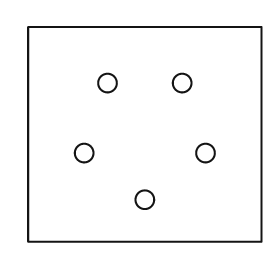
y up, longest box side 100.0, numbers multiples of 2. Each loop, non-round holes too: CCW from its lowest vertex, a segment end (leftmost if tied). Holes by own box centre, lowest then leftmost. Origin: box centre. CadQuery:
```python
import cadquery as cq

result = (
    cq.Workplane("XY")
    .moveTo(-50.0, -46.0)
    .lineTo(50.0, -46.0)
    .lineTo(50.0, 46.0)
    .lineTo(-50.0, 46.0)
    .close()
    .moveTo(0.0, -28.0)
    .circle(4.0)
    .moveTo(-26.0, -8.0)
    .circle(4.0)
    .moveTo(26.0, -8.0)
    .circle(4.0)
    .moveTo(-16.0, 22.0)
    .circle(4.0)
    .moveTo(16.0, 22.0)
    .circle(4.0)
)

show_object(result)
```